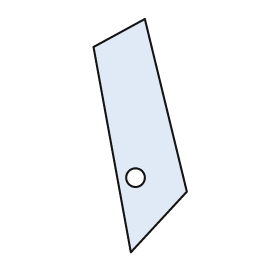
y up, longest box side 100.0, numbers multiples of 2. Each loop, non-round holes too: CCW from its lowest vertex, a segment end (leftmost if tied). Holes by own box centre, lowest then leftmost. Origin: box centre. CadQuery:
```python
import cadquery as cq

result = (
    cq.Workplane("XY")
    .moveTo(-4.0, -50.0)
    .lineTo(20.0, -24.0)
    .lineTo(2.0, 50.0)
    .lineTo(-20.0, 38.0)
    .close()
    .moveTo(-2.0, -18.0)
    .circle(4.0)
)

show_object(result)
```